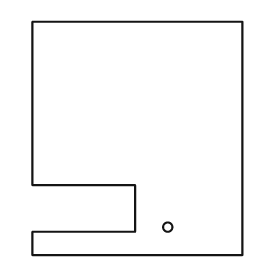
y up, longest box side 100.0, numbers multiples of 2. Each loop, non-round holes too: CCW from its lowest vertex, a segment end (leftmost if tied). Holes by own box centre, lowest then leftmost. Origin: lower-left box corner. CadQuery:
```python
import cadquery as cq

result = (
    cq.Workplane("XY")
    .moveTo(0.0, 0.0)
    .lineTo(90.0, 0.0)
    .lineTo(90.0, 100.0)
    .lineTo(0.0, 100.0)
    .lineTo(0.0, 30.0)
    .lineTo(44.0, 30.0)
    .lineTo(44.0, 10.0)
    .lineTo(0.0, 10.0)
    .close()
    .moveTo(58.0, 12.0)
    .circle(2.0)
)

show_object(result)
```